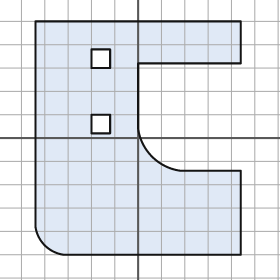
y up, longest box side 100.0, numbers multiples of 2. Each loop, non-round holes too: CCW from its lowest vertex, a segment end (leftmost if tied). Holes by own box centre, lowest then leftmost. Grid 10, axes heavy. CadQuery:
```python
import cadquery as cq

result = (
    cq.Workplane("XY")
    .moveTo(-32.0, -50.0)
    .lineTo(44.0, -50.0)
    .lineTo(44.0, -14.0)
    .lineTo(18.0, -14.0)
    .threePointArc((6.0, -8.0), (0.0, 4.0))
    .lineTo(0.0, 32.0)
    .lineTo(44.0, 32.0)
    .lineTo(44.0, 50.0)
    .lineTo(-44.0, 50.0)
    .lineTo(-44.0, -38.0)
    .threePointArc((-40.0, -46.0), (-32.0, -50.0))
    .close()
    .moveTo(-20.0, 2.0)
    .lineTo(-12.0, 2.0)
    .lineTo(-12.0, 10.0)
    .lineTo(-20.0, 10.0)
    .close()
    .moveTo(-20.0, 30.0)
    .lineTo(-12.0, 30.0)
    .lineTo(-12.0, 38.0)
    .lineTo(-20.0, 38.0)
    .close()
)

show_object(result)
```